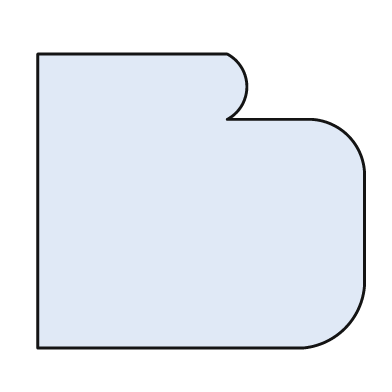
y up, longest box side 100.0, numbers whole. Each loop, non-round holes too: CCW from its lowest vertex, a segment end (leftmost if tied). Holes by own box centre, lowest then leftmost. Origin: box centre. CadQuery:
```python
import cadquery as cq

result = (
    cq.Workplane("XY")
    .moveTo(-50.0, -45.0)
    .lineTo(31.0, -45.0)
    .threePointArc((44.0, -39.0), (50.0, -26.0))
    .lineTo(50.0, 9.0)
    .threePointArc((45.0, 20.0), (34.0, 25.0))
    .lineTo(8.0, 25.0)
    .threePointArc((14.0, 35.0), (8.0, 45.0))
    .lineTo(-50.0, 45.0)
    .close()
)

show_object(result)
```